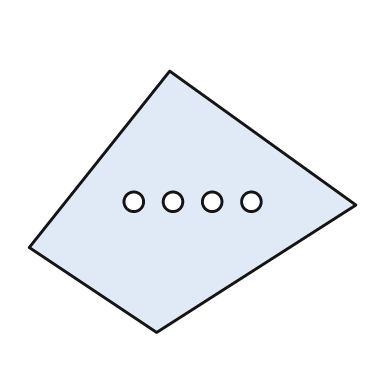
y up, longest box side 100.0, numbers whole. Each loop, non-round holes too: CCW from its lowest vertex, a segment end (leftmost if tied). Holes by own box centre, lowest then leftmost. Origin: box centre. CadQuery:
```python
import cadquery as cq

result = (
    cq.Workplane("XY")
    .moveTo(-11.0, -40.0)
    .lineTo(50.0, -1.0)
    .lineTo(-7.0, 40.0)
    .lineTo(-50.0, -14.0)
    .close()
    .moveTo(-18.0, 0.0)
    .circle(3.0)
    .moveTo(-6.0, 0.0)
    .circle(3.0)
    .moveTo(6.0, 0.0)
    .circle(3.0)
    .moveTo(18.0, 0.0)
    .circle(3.0)
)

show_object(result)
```